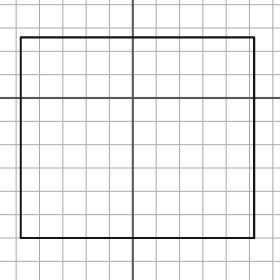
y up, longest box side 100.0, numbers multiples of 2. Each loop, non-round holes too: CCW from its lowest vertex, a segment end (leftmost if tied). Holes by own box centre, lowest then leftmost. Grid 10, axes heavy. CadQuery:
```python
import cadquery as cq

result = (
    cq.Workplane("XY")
    .moveTo(-48.0, -60.0)
    .lineTo(52.0, -60.0)
    .lineTo(52.0, 26.0)
    .lineTo(-48.0, 26.0)
    .close()
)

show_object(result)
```